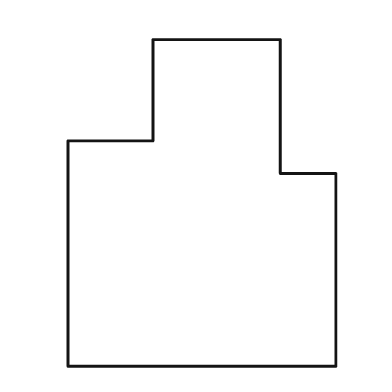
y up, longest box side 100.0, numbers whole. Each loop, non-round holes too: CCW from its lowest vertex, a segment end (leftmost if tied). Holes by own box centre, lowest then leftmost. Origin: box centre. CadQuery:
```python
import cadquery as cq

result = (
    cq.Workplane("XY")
    .moveTo(-41.0, -50.0)
    .lineTo(41.0, -50.0)
    .lineTo(41.0, 9.0)
    .lineTo(24.0, 9.0)
    .lineTo(24.0, 50.0)
    .lineTo(-15.0, 50.0)
    .lineTo(-15.0, 19.0)
    .lineTo(-41.0, 19.0)
    .close()
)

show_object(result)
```